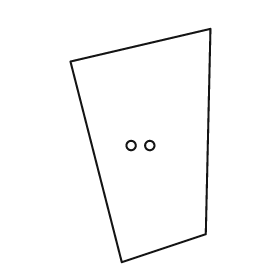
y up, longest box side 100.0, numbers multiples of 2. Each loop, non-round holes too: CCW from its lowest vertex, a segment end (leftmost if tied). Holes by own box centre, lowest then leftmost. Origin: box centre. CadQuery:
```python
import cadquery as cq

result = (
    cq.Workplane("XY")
    .moveTo(-8.0, -50.0)
    .lineTo(28.0, -38.0)
    .lineTo(30.0, 50.0)
    .lineTo(-30.0, 36.0)
    .close()
    .moveTo(-4.0, 0.0)
    .circle(2.0)
    .moveTo(4.0, 0.0)
    .circle(2.0)
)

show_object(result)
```